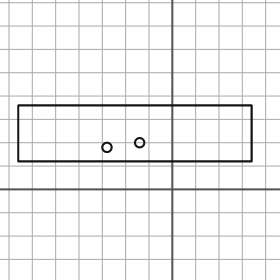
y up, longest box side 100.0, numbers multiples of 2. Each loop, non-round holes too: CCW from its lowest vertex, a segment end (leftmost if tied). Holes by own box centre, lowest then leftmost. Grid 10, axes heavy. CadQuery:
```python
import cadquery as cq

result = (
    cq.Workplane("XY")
    .moveTo(-66.0, 12.0)
    .lineTo(34.0, 12.0)
    .lineTo(34.0, 36.0)
    .lineTo(-66.0, 36.0)
    .close()
    .moveTo(-28.0, 18.0)
    .circle(2.0)
    .moveTo(-14.0, 20.0)
    .circle(2.0)
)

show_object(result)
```